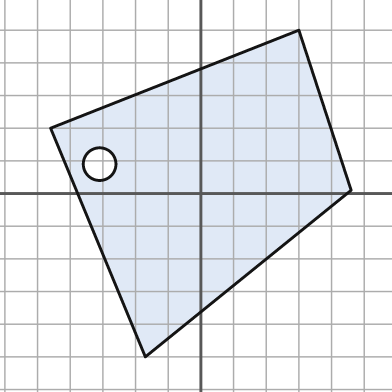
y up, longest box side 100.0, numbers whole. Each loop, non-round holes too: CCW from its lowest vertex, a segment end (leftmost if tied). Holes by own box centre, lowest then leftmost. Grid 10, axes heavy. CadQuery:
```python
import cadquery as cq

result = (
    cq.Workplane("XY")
    .moveTo(-17.0, -50.0)
    .lineTo(46.0, 1.0)
    .lineTo(30.0, 50.0)
    .lineTo(-46.0, 20.0)
    .close()
    .moveTo(-31.0, 9.0)
    .circle(5.0)
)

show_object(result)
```